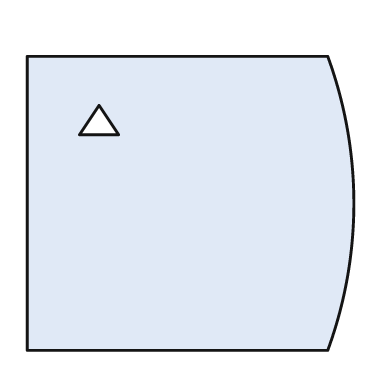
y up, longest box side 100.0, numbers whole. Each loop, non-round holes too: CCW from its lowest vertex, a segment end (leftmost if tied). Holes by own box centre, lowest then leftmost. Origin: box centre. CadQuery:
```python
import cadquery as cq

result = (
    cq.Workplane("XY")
    .moveTo(-50.0, -45.0)
    .lineTo(42.0, -45.0)
    .threePointArc((50.0, 0.0), (42.0, 45.0))
    .lineTo(-50.0, 45.0)
    .close()
    .moveTo(-34.0, 21.0)
    .lineTo(-22.0, 21.0)
    .lineTo(-28.0, 30.0)
    .close()
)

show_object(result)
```